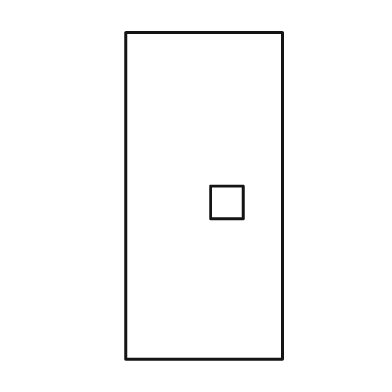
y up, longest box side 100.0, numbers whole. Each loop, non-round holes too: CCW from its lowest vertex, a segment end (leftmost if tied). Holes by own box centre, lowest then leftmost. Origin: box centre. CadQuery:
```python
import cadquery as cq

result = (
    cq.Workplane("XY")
    .moveTo(-24.0, -50.0)
    .lineTo(24.0, -50.0)
    .lineTo(24.0, 50.0)
    .lineTo(-24.0, 50.0)
    .close()
    .moveTo(2.0, -7.0)
    .lineTo(12.0, -7.0)
    .lineTo(12.0, 3.0)
    .lineTo(2.0, 3.0)
    .close()
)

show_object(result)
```